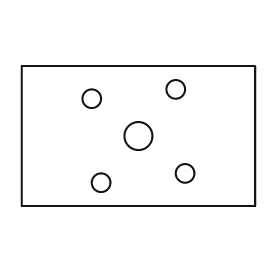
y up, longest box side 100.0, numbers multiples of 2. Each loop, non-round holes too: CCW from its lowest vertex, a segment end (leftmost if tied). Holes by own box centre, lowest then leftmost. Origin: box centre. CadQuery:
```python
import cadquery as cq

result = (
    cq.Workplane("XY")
    .moveTo(-50.0, -30.0)
    .lineTo(50.0, -30.0)
    .lineTo(50.0, 30.0)
    .lineTo(-50.0, 30.0)
    .close()
    .moveTo(-16.0, -20.0)
    .circle(4.0)
    .moveTo(20.0, -16.0)
    .circle(4.0)
    .moveTo(0.0, 0.0)
    .circle(6.0)
    .moveTo(-20.0, 16.0)
    .circle(4.0)
    .moveTo(16.0, 20.0)
    .circle(4.0)
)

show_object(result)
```